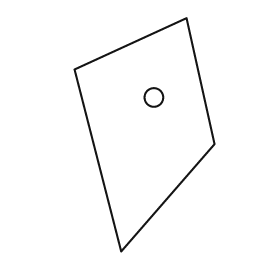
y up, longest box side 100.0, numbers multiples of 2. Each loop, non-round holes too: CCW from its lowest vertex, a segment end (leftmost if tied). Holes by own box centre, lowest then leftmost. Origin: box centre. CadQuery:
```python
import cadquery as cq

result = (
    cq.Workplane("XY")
    .moveTo(-10.0, -50.0)
    .lineTo(30.0, -4.0)
    .lineTo(18.0, 50.0)
    .lineTo(-30.0, 28.0)
    .close()
    .moveTo(4.0, 16.0)
    .circle(4.0)
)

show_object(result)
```